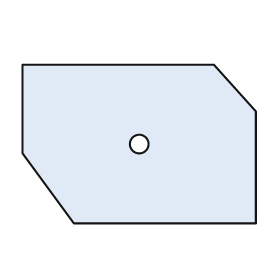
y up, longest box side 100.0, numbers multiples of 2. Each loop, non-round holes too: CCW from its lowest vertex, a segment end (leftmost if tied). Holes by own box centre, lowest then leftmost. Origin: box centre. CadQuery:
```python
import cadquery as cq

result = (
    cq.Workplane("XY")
    .moveTo(-28.0, -34.0)
    .lineTo(50.0, -34.0)
    .lineTo(50.0, 14.0)
    .lineTo(32.0, 34.0)
    .lineTo(-50.0, 34.0)
    .lineTo(-50.0, -4.0)
    .close()
    .moveTo(0.0, 0.0)
    .circle(4.0)
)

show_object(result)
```